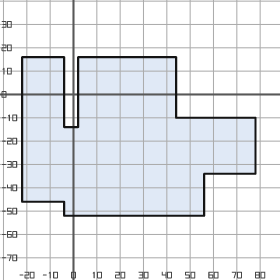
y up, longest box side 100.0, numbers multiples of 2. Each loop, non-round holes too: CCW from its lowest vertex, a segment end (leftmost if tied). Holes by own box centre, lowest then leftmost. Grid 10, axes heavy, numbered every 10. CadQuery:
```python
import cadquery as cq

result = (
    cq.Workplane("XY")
    .moveTo(-4.0, -52.0)
    .lineTo(56.0, -52.0)
    .lineTo(56.0, -34.0)
    .lineTo(78.0, -34.0)
    .lineTo(78.0, -10.0)
    .lineTo(44.0, -10.0)
    .lineTo(44.0, 16.0)
    .lineTo(2.0, 16.0)
    .lineTo(2.0, -14.0)
    .lineTo(-4.0, -14.0)
    .lineTo(-4.0, 16.0)
    .lineTo(-22.0, 16.0)
    .lineTo(-22.0, -46.0)
    .lineTo(-4.0, -46.0)
    .close()
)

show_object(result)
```